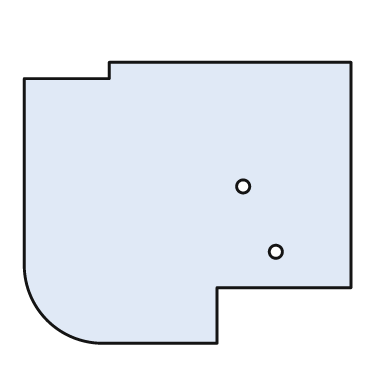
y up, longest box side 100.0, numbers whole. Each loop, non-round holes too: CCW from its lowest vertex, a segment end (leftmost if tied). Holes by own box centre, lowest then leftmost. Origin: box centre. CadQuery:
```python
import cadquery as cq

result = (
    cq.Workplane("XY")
    .moveTo(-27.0, -43.0)
    .lineTo(9.0, -43.0)
    .lineTo(9.0, -26.0)
    .lineTo(50.0, -26.0)
    .lineTo(50.0, 43.0)
    .lineTo(-24.0, 43.0)
    .lineTo(-24.0, 38.0)
    .lineTo(-50.0, 38.0)
    .lineTo(-50.0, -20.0)
    .threePointArc((-43.0, -36.0), (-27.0, -43.0))
    .close()
    .moveTo(27.0, -15.0)
    .circle(2.0)
    .moveTo(17.0, 5.0)
    .circle(2.0)
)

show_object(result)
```